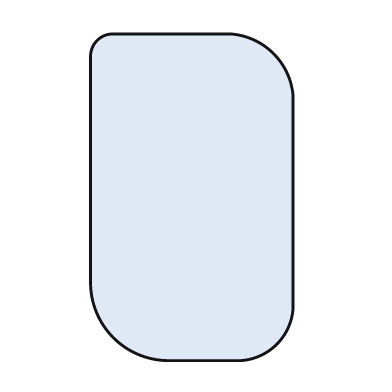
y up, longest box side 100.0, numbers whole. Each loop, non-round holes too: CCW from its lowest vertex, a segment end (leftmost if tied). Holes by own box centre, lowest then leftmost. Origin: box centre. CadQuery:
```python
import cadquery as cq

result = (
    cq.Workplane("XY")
    .moveTo(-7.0, -50.0)
    .lineTo(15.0, -50.0)
    .threePointArc((26.0, -45.0), (31.0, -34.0))
    .lineTo(31.0, 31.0)
    .threePointArc((25.0, 44.0), (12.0, 50.0))
    .lineTo(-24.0, 50.0)
    .threePointArc((-29.0, 48.0), (-31.0, 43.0))
    .lineTo(-31.0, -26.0)
    .threePointArc((-24.0, -43.0), (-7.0, -50.0))
    .close()
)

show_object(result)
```